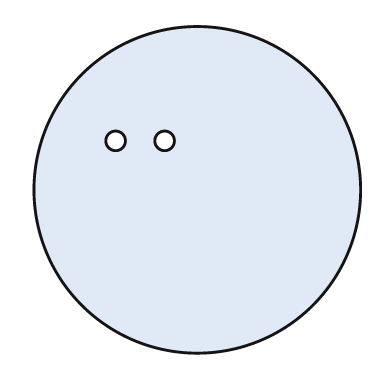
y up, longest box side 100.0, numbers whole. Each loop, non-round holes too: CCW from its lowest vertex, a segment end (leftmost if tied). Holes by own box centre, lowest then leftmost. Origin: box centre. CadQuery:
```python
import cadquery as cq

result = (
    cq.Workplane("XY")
    .moveTo(0.0, 0.0)
    .circle(50.0)
    .moveTo(-25.0, 15.0)
    .circle(3.0)
    .moveTo(-10.0, 15.0)
    .circle(3.0)
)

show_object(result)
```